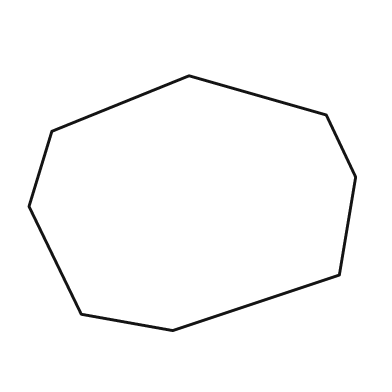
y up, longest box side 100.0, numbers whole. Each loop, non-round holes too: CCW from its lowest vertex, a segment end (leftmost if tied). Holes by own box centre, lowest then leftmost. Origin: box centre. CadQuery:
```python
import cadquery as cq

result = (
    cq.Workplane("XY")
    .moveTo(-6.0, -39.0)
    .lineTo(45.0, -22.0)
    .lineTo(50.0, 8.0)
    .lineTo(41.0, 27.0)
    .lineTo(-1.0, 39.0)
    .lineTo(-43.0, 22.0)
    .lineTo(-50.0, -1.0)
    .lineTo(-34.0, -34.0)
    .close()
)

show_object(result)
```